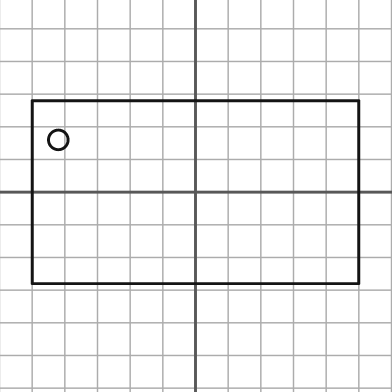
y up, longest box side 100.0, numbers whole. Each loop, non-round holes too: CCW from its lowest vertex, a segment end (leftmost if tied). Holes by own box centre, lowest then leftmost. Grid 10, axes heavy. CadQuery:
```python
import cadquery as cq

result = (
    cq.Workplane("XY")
    .moveTo(-50.0, -28.0)
    .lineTo(50.0, -28.0)
    .lineTo(50.0, 28.0)
    .lineTo(-50.0, 28.0)
    .close()
    .moveTo(-42.0, 16.0)
    .circle(3.0)
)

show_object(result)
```